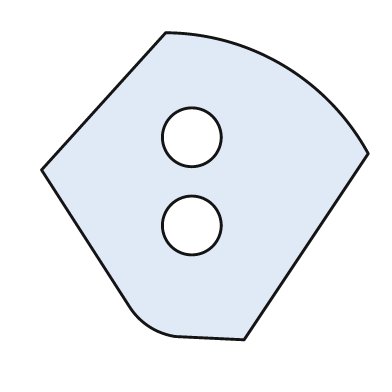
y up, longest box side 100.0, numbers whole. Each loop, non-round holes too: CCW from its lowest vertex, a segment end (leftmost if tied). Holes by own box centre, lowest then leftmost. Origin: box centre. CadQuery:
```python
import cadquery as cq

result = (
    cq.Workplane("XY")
    .moveTo(12.0, -47.0)
    .lineTo(50.0, 10.0)
    .threePointArc((24.0, 37.0), (-12.0, 47.0))
    .lineTo(-50.0, 5.0)
    .lineTo(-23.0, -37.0)
    .threePointArc((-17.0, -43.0), (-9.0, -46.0))
    .close()
    .moveTo(-4.0, -12.0)
    .circle(9.0)
    .moveTo(-4.0, 15.0)
    .circle(9.0)
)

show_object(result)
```